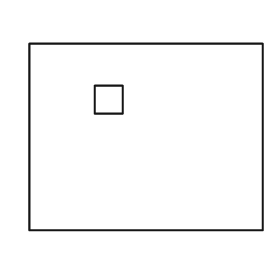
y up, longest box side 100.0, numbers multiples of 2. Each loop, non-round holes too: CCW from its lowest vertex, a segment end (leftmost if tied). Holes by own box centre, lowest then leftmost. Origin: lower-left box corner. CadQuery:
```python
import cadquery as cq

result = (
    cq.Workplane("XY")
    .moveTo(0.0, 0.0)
    .lineTo(100.0, 0.0)
    .lineTo(100.0, 80.0)
    .lineTo(0.0, 80.0)
    .close()
    .moveTo(28.0, 50.0)
    .lineTo(40.0, 50.0)
    .lineTo(40.0, 62.0)
    .lineTo(28.0, 62.0)
    .close()
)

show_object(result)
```